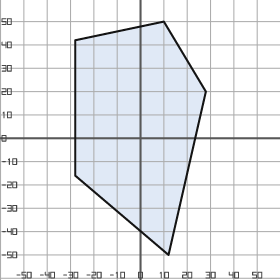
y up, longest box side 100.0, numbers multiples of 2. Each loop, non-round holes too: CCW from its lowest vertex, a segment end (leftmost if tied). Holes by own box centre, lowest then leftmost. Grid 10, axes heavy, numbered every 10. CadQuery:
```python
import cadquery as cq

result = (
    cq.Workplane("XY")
    .moveTo(12.0, -50.0)
    .lineTo(28.0, 20.0)
    .lineTo(10.0, 50.0)
    .lineTo(-28.0, 42.0)
    .lineTo(-28.0, -16.0)
    .close()
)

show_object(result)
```